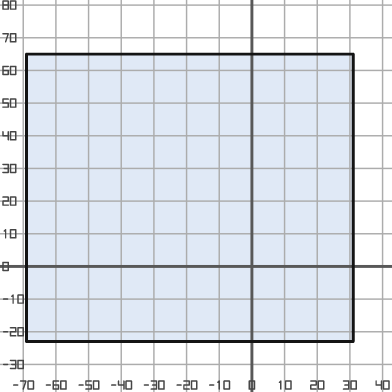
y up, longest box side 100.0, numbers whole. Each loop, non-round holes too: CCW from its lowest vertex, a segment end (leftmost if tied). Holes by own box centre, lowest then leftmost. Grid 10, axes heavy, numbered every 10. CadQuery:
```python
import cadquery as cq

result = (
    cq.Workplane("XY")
    .moveTo(-69.0, -23.0)
    .lineTo(31.0, -23.0)
    .lineTo(31.0, 65.0)
    .lineTo(-69.0, 65.0)
    .close()
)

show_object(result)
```